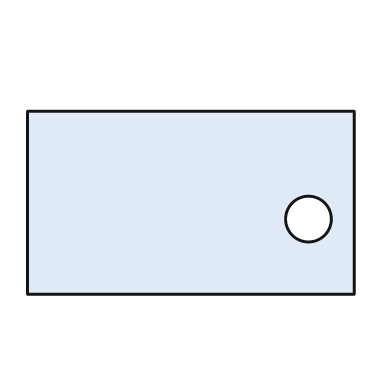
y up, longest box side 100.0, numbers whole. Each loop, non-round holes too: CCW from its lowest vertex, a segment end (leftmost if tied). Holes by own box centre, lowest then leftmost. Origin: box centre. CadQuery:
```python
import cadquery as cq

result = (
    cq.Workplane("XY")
    .moveTo(-50.0, -28.0)
    .lineTo(50.0, -28.0)
    .lineTo(50.0, 28.0)
    .lineTo(-50.0, 28.0)
    .close()
    .moveTo(36.0, -5.0)
    .circle(7.0)
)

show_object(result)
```